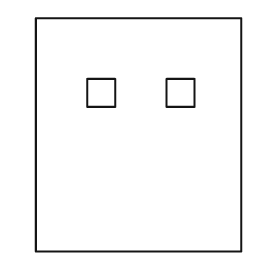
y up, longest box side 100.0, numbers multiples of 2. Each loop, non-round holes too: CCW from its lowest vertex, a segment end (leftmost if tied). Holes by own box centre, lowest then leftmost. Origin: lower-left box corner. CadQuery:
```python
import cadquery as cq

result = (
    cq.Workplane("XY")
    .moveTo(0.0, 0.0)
    .lineTo(88.0, 0.0)
    .lineTo(88.0, 100.0)
    .lineTo(0.0, 100.0)
    .close()
    .moveTo(22.0, 62.0)
    .lineTo(34.0, 62.0)
    .lineTo(34.0, 74.0)
    .lineTo(22.0, 74.0)
    .close()
    .moveTo(56.0, 62.0)
    .lineTo(68.0, 62.0)
    .lineTo(68.0, 74.0)
    .lineTo(56.0, 74.0)
    .close()
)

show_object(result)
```